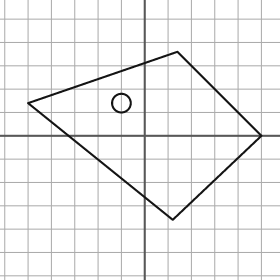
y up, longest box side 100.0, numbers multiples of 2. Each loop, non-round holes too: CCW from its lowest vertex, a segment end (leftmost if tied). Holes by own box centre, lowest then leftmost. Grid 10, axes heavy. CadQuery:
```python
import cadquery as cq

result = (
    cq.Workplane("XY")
    .moveTo(12.0, -36.0)
    .lineTo(50.0, 0.0)
    .lineTo(14.0, 36.0)
    .lineTo(-50.0, 14.0)
    .close()
    .moveTo(-10.0, 14.0)
    .circle(4.0)
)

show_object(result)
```